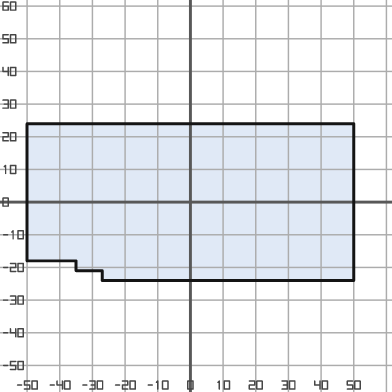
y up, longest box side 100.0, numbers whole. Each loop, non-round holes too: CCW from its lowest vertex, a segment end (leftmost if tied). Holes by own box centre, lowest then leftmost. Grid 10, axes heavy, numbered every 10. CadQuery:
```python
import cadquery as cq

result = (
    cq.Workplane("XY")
    .moveTo(-27.0, -24.0)
    .lineTo(50.0, -24.0)
    .lineTo(50.0, 24.0)
    .lineTo(-50.0, 24.0)
    .lineTo(-50.0, -18.0)
    .lineTo(-35.0, -18.0)
    .lineTo(-35.0, -21.0)
    .lineTo(-27.0, -21.0)
    .close()
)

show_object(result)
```